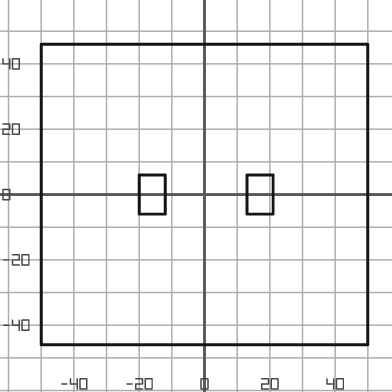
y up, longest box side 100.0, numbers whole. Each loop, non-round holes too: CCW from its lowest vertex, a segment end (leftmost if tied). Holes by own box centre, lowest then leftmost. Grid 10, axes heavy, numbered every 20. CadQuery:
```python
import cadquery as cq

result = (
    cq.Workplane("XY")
    .moveTo(-50.0, -46.0)
    .lineTo(50.0, -46.0)
    .lineTo(50.0, 46.0)
    .lineTo(-50.0, 46.0)
    .close()
    .moveTo(-20.0, -6.0)
    .lineTo(-12.0, -6.0)
    .lineTo(-12.0, 6.0)
    .lineTo(-20.0, 6.0)
    .close()
    .moveTo(13.0, -6.0)
    .lineTo(21.0, -6.0)
    .lineTo(21.0, 6.0)
    .lineTo(13.0, 6.0)
    .close()
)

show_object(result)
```